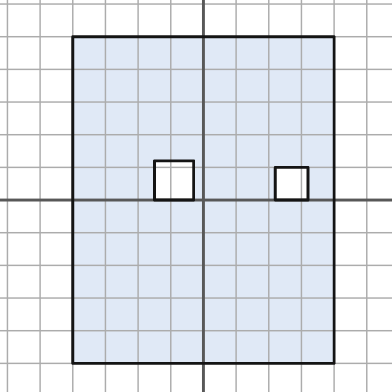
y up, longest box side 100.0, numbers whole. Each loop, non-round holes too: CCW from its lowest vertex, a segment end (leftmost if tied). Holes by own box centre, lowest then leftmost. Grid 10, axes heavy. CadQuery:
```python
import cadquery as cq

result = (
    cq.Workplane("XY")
    .moveTo(-40.0, -50.0)
    .lineTo(40.0, -50.0)
    .lineTo(40.0, 50.0)
    .lineTo(-40.0, 50.0)
    .close()
    .moveTo(22.0, 0.0)
    .lineTo(32.0, 0.0)
    .lineTo(32.0, 10.0)
    .lineTo(22.0, 10.0)
    .close()
    .moveTo(-15.0, 0.0)
    .lineTo(-3.0, 0.0)
    .lineTo(-3.0, 12.0)
    .lineTo(-15.0, 12.0)
    .close()
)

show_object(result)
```